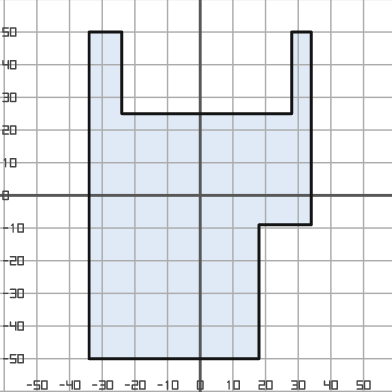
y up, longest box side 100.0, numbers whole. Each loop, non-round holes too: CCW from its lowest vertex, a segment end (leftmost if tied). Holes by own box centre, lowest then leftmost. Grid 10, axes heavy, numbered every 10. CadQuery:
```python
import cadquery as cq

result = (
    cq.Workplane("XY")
    .moveTo(-34.0, -50.0)
    .lineTo(18.0, -50.0)
    .lineTo(18.0, -9.0)
    .lineTo(34.0, -9.0)
    .lineTo(34.0, 50.0)
    .lineTo(28.0, 50.0)
    .lineTo(28.0, 25.0)
    .lineTo(-24.0, 25.0)
    .lineTo(-24.0, 50.0)
    .lineTo(-34.0, 50.0)
    .close()
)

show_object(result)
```